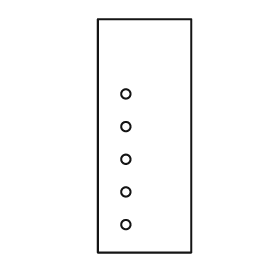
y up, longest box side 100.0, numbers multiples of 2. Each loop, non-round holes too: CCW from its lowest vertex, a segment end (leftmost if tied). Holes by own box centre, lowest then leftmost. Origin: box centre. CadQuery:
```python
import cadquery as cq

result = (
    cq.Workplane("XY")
    .moveTo(-20.0, -50.0)
    .lineTo(20.0, -50.0)
    .lineTo(20.0, 50.0)
    .lineTo(-20.0, 50.0)
    .close()
    .moveTo(-8.0, -38.0)
    .circle(2.0)
    .moveTo(-8.0, -24.0)
    .circle(2.0)
    .moveTo(-8.0, -10.0)
    .circle(2.0)
    .moveTo(-8.0, 4.0)
    .circle(2.0)
    .moveTo(-8.0, 18.0)
    .circle(2.0)
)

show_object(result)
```